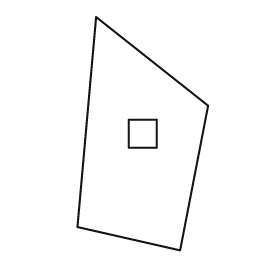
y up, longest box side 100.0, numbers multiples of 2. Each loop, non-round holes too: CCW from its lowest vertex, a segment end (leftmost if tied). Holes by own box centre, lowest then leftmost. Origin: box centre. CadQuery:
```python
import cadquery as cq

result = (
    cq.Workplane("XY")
    .moveTo(16.0, -50.0)
    .lineTo(28.0, 12.0)
    .lineTo(-20.0, 50.0)
    .lineTo(-28.0, -40.0)
    .close()
    .moveTo(-6.0, -6.0)
    .lineTo(6.0, -6.0)
    .lineTo(6.0, 6.0)
    .lineTo(-6.0, 6.0)
    .close()
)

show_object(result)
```